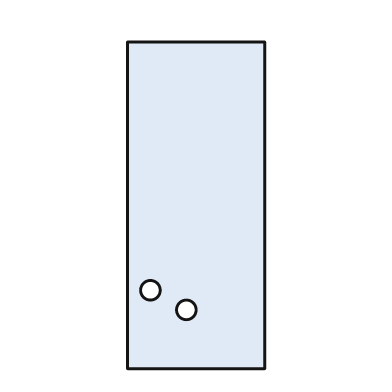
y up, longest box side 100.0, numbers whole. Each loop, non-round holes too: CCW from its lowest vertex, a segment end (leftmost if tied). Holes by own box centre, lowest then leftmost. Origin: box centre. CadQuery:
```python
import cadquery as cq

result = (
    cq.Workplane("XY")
    .moveTo(-21.0, -50.0)
    .lineTo(21.0, -50.0)
    .lineTo(21.0, 50.0)
    .lineTo(-21.0, 50.0)
    .close()
    .moveTo(-3.0, -32.0)
    .circle(3.0)
    .moveTo(-14.0, -26.0)
    .circle(3.0)
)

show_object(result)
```